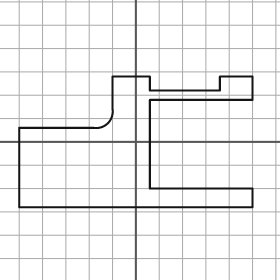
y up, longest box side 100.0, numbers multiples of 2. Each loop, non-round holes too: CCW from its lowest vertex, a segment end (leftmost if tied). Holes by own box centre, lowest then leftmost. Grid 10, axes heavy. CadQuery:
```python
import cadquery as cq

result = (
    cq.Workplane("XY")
    .moveTo(-50.0, -28.0)
    .lineTo(50.0, -28.0)
    .lineTo(50.0, -20.0)
    .lineTo(6.0, -20.0)
    .lineTo(6.0, 18.0)
    .lineTo(50.0, 18.0)
    .lineTo(50.0, 28.0)
    .lineTo(36.0, 28.0)
    .lineTo(36.0, 22.0)
    .lineTo(6.0, 22.0)
    .lineTo(6.0, 28.0)
    .lineTo(-10.0, 28.0)
    .lineTo(-10.0, 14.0)
    .threePointArc((-12.0, 8.0), (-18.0, 6.0))
    .lineTo(-50.0, 6.0)
    .close()
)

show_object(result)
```